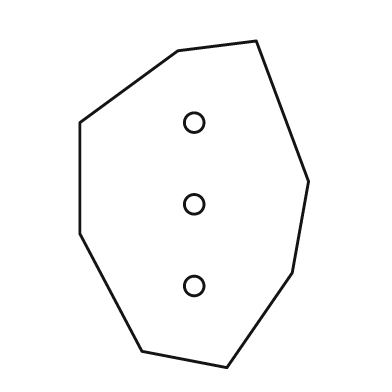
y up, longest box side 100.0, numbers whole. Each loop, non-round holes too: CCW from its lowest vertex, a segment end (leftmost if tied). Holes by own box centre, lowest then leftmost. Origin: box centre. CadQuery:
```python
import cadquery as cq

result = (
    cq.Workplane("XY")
    .moveTo(10.0, -50.0)
    .lineTo(30.0, -21.0)
    .lineTo(35.0, 7.0)
    .lineTo(19.0, 50.0)
    .lineTo(-5.0, 47.0)
    .lineTo(-35.0, 25.0)
    .lineTo(-35.0, -9.0)
    .lineTo(-16.0, -45.0)
    .close()
    .moveTo(0.0, -25.0)
    .circle(3.0)
    .moveTo(0.0, 0.0)
    .circle(3.0)
    .moveTo(0.0, 25.0)
    .circle(3.0)
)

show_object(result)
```